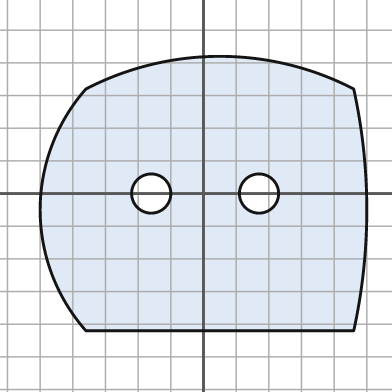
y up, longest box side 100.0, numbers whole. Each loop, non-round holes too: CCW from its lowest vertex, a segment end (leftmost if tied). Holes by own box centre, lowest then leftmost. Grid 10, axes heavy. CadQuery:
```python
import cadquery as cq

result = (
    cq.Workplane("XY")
    .moveTo(-36.0, -42.0)
    .lineTo(46.0, -42.0)
    .threePointArc((50.0, -5.0), (46.0, 32.0))
    .threePointArc((5.0, 42.0), (-36.0, 32.0))
    .threePointArc((-50.0, -5.0), (-36.0, -42.0))
    .close()
    .moveTo(-16.0, 0.0)
    .circle(6.0)
    .moveTo(17.0, 0.0)
    .circle(6.0)
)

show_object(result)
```